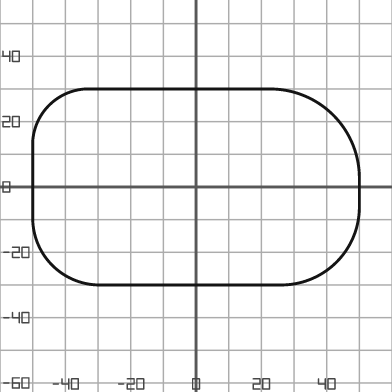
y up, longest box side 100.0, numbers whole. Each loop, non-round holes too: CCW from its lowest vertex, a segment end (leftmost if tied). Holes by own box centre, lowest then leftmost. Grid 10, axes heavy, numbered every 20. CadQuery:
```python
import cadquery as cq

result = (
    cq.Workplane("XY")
    .moveTo(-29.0, -30.0)
    .lineTo(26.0, -30.0)
    .threePointArc((43.0, -23.0), (50.0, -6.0))
    .lineTo(50.0, 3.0)
    .threePointArc((42.0, 22.0), (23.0, 30.0))
    .lineTo(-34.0, 30.0)
    .threePointArc((-45.0, 25.0), (-50.0, 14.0))
    .lineTo(-50.0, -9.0)
    .threePointArc((-44.0, -24.0), (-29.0, -30.0))
    .close()
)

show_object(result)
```